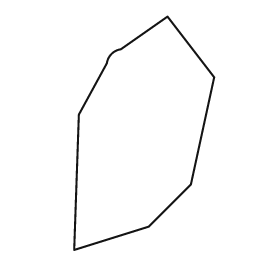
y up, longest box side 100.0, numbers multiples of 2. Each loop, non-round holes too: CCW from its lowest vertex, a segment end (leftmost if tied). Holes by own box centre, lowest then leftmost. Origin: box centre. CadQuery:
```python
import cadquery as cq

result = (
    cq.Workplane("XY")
    .moveTo(-30.0, -50.0)
    .lineTo(2.0, -40.0)
    .lineTo(20.0, -22.0)
    .lineTo(30.0, 24.0)
    .lineTo(10.0, 50.0)
    .lineTo(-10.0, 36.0)
    .threePointArc((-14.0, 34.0), (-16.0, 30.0))
    .lineTo(-28.0, 8.0)
    .close()
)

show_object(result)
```